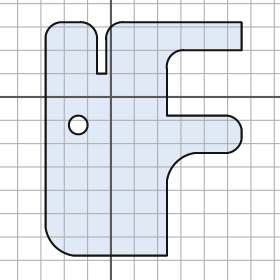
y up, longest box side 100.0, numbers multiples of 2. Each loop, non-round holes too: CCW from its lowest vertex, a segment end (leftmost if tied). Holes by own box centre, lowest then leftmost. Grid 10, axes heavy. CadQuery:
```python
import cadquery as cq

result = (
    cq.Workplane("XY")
    .moveTo(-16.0, -68.0)
    .lineTo(24.0, -68.0)
    .lineTo(24.0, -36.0)
    .threePointArc((28.0, -28.0), (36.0, -24.0))
    .lineTo(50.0, -24.0)
    .threePointArc((54.0, -22.0), (56.0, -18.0))
    .lineTo(56.0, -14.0)
    .threePointArc((54.0, -10.0), (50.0, -8.0))
    .lineTo(24.0, -8.0)
    .lineTo(24.0, 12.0)
    .threePointArc((26.0, 18.0), (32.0, 20.0))
    .lineTo(56.0, 20.0)
    .lineTo(56.0, 32.0)
    .lineTo(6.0, 32.0)
    .threePointArc((0.0, 30.0), (-2.0, 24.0))
    .lineTo(-2.0, 10.0)
    .lineTo(-6.0, 10.0)
    .lineTo(-6.0, 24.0)
    .threePointArc((-8.0, 30.0), (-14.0, 32.0))
    .lineTo(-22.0, 32.0)
    .threePointArc((-26.0, 30.0), (-28.0, 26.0))
    .lineTo(-28.0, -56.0)
    .threePointArc((-24.0, -64.0), (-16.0, -68.0))
    .close()
    .moveTo(-14.0, -12.0)
    .circle(4.0)
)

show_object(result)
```